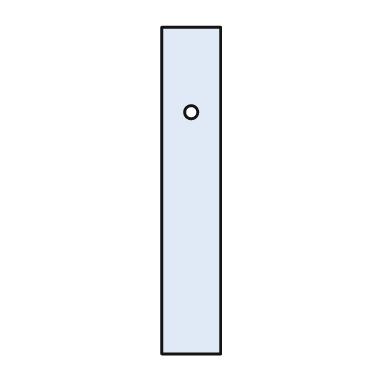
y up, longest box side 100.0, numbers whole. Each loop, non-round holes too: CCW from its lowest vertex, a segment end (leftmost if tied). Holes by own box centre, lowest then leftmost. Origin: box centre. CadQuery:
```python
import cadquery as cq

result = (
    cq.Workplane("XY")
    .moveTo(-9.0, -50.0)
    .lineTo(9.0, -50.0)
    .lineTo(9.0, 50.0)
    .lineTo(-9.0, 50.0)
    .close()
    .moveTo(0.0, 24.0)
    .circle(2.0)
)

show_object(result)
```